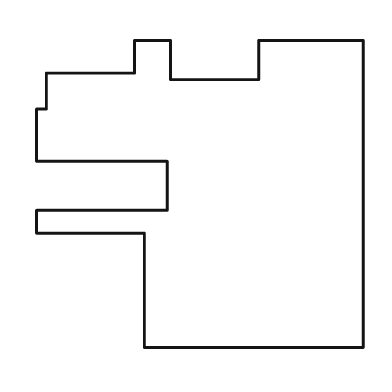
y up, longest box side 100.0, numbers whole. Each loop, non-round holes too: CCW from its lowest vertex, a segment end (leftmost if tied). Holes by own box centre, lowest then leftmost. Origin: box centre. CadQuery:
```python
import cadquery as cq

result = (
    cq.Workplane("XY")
    .moveTo(-17.0, -47.0)
    .lineTo(50.0, -47.0)
    .lineTo(50.0, 47.0)
    .lineTo(18.0, 47.0)
    .lineTo(18.0, 35.0)
    .lineTo(-9.0, 35.0)
    .lineTo(-9.0, 47.0)
    .lineTo(-20.0, 47.0)
    .lineTo(-20.0, 37.0)
    .lineTo(-47.0, 37.0)
    .lineTo(-47.0, 26.0)
    .lineTo(-50.0, 26.0)
    .lineTo(-50.0, 10.0)
    .lineTo(-10.0, 10.0)
    .lineTo(-10.0, -5.0)
    .lineTo(-50.0, -5.0)
    .lineTo(-50.0, -12.0)
    .lineTo(-17.0, -12.0)
    .close()
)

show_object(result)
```